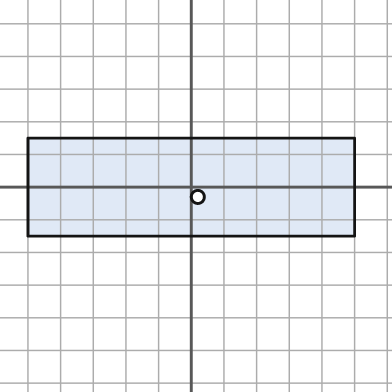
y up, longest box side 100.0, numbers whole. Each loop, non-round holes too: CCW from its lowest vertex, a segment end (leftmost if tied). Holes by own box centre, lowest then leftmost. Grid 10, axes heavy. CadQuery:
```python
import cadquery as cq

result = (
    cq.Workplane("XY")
    .moveTo(-50.0, -15.0)
    .lineTo(50.0, -15.0)
    .lineTo(50.0, 15.0)
    .lineTo(-50.0, 15.0)
    .close()
    .moveTo(2.0, -3.0)
    .circle(2.0)
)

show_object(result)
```